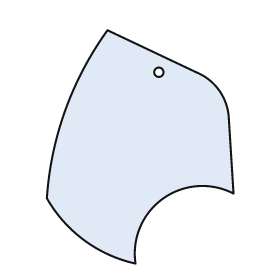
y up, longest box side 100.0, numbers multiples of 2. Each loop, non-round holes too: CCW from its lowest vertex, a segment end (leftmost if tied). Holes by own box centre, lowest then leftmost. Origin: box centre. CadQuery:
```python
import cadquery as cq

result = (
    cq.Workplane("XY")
    .moveTo(-2.0, -50.0)
    .threePointArc((10.0, -22.0), (40.0, -20.0))
    .lineTo(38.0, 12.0)
    .threePointArc((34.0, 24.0), (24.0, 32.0))
    .lineTo(-14.0, 50.0)
    .threePointArc((-32.0, 16.0), (-40.0, -22.0))
    .threePointArc((-24.0, -40.0), (-2.0, -50.0))
    .close()
    .moveTo(8.0, 32.0)
    .circle(2.0)
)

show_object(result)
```